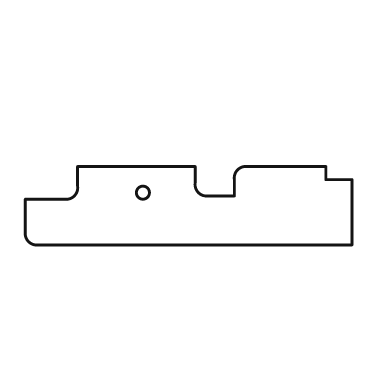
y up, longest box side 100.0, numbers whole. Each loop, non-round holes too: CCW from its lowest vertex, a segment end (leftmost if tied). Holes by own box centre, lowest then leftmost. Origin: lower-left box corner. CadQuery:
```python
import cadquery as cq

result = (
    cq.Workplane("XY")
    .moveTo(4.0, 0.0)
    .lineTo(100.0, 0.0)
    .lineTo(100.0, 20.0)
    .lineTo(92.0, 20.0)
    .lineTo(92.0, 24.0)
    .lineTo(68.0, 24.0)
    .threePointArc((65.0, 23.0), (64.0, 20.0))
    .lineTo(64.0, 15.0)
    .lineTo(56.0, 15.0)
    .threePointArc((53.0, 16.0), (52.0, 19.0))
    .lineTo(52.0, 24.0)
    .lineTo(16.0, 24.0)
    .lineTo(16.0, 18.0)
    .threePointArc((15.0, 15.0), (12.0, 14.0))
    .lineTo(0.0, 14.0)
    .lineTo(0.0, 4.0)
    .threePointArc((1.0, 1.0), (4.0, 0.0))
    .close()
    .moveTo(36.0, 16.0)
    .circle(2.0)
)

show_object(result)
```